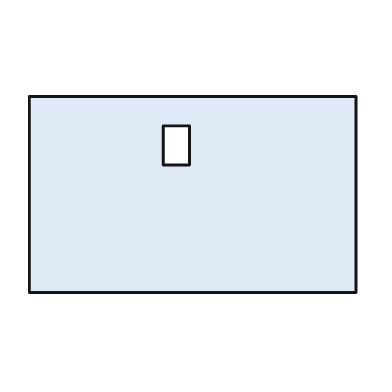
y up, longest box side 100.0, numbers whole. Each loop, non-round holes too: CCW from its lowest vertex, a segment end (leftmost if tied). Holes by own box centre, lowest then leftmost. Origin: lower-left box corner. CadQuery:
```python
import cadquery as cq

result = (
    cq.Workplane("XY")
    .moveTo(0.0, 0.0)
    .lineTo(100.0, 0.0)
    .lineTo(100.0, 60.0)
    .lineTo(0.0, 60.0)
    .close()
    .moveTo(41.0, 39.0)
    .lineTo(49.0, 39.0)
    .lineTo(49.0, 51.0)
    .lineTo(41.0, 51.0)
    .close()
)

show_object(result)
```